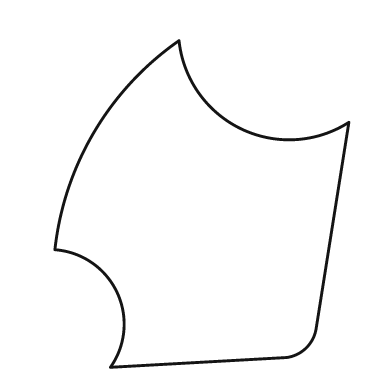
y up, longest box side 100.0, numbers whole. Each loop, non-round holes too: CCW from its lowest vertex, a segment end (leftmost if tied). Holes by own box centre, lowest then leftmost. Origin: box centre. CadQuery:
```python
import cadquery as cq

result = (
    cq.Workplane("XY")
    .moveTo(-28.0, -50.0)
    .lineTo(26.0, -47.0)
    .threePointArc((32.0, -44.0), (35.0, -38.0))
    .lineTo(45.0, 25.0)
    .threePointArc((12.0, 23.0), (-7.0, 50.0))
    .threePointArc((-33.0, 22.0), (-45.0, -14.0))
    .threePointArc((-26.0, -27.0), (-28.0, -50.0))
    .close()
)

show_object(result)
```